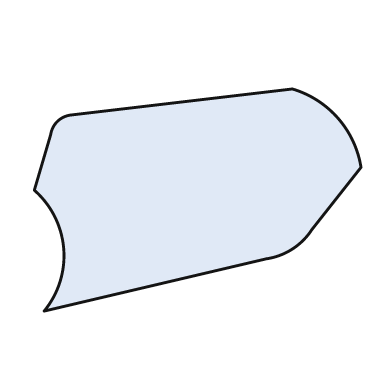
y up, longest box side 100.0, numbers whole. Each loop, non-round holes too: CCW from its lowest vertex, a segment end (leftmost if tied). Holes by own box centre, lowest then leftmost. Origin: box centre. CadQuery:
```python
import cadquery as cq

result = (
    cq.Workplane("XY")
    .moveTo(-47.0, -34.0)
    .lineTo(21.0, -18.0)
    .threePointArc((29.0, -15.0), (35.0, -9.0))
    .lineTo(50.0, 10.0)
    .threePointArc((43.0, 25.0), (29.0, 34.0))
    .lineTo(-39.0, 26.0)
    .threePointArc((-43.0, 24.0), (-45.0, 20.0))
    .lineTo(-50.0, 3.0)
    .threePointArc((-41.0, -15.0), (-47.0, -34.0))
    .close()
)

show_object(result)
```